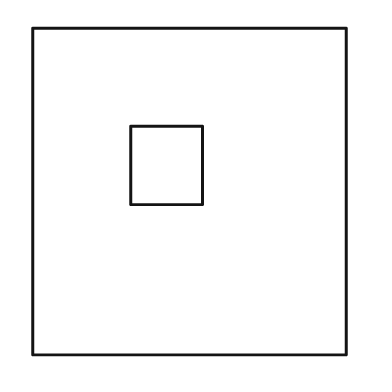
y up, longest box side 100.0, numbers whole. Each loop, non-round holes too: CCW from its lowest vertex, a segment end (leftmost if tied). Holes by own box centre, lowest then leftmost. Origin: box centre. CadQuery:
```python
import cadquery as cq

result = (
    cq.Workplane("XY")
    .moveTo(-48.0, -50.0)
    .lineTo(48.0, -50.0)
    .lineTo(48.0, 50.0)
    .lineTo(-48.0, 50.0)
    .close()
    .moveTo(-18.0, -4.0)
    .lineTo(4.0, -4.0)
    .lineTo(4.0, 20.0)
    .lineTo(-18.0, 20.0)
    .close()
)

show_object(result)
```